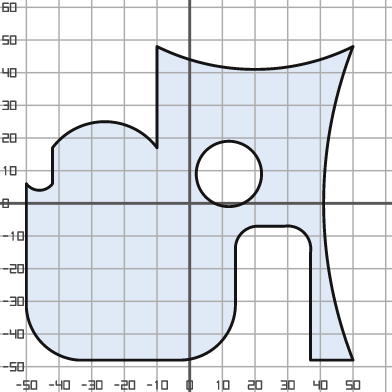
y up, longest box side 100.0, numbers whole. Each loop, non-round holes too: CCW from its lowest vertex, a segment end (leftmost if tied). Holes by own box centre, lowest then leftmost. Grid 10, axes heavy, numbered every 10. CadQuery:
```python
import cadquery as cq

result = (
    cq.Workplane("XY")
    .moveTo(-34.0, -48.0)
    .lineTo(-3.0, -48.0)
    .threePointArc((9.0, -43.0), (14.0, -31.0))
    .lineTo(14.0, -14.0)
    .threePointArc((16.0, -9.0), (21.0, -7.0))
    .lineTo(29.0, -7.0)
    .threePointArc((35.0, -9.0), (37.0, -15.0))
    .lineTo(37.0, -48.0)
    .lineTo(50.0, -48.0)
    .threePointArc((41.0, 0.0), (50.0, 48.0))
    .threePointArc((20.0, 41.0), (-10.0, 48.0))
    .lineTo(-10.0, 17.0)
    .threePointArc((-26.0, 25.0), (-42.0, 17.0))
    .lineTo(-42.0, 6.0)
    .threePointArc((-46.0, 4.0), (-50.0, 6.0))
    .lineTo(-50.0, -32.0)
    .threePointArc((-45.0, -43.0), (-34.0, -48.0))
    .close()
    .moveTo(12.0, 9.0)
    .circle(10.0)
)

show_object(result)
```